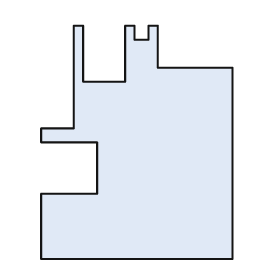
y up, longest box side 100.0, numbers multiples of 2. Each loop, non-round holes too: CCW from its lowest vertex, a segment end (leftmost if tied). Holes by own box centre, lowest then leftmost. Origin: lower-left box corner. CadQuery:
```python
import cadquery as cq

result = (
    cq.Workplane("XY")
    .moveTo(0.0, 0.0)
    .lineTo(82.0, 0.0)
    .lineTo(82.0, 82.0)
    .lineTo(50.0, 82.0)
    .lineTo(50.0, 100.0)
    .lineTo(46.0, 100.0)
    .lineTo(46.0, 94.0)
    .lineTo(40.0, 94.0)
    .lineTo(40.0, 100.0)
    .lineTo(36.0, 100.0)
    .lineTo(36.0, 76.0)
    .lineTo(18.0, 76.0)
    .lineTo(18.0, 100.0)
    .lineTo(14.0, 100.0)
    .lineTo(14.0, 56.0)
    .lineTo(0.0, 56.0)
    .lineTo(0.0, 50.0)
    .lineTo(24.0, 50.0)
    .lineTo(24.0, 28.0)
    .lineTo(0.0, 28.0)
    .close()
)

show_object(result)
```